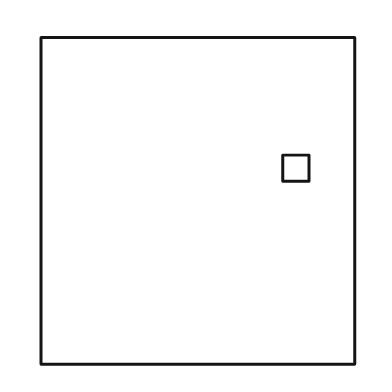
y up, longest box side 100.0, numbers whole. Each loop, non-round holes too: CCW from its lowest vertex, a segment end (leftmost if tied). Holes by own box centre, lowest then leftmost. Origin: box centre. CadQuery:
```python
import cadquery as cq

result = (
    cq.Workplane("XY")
    .moveTo(-48.0, -50.0)
    .lineTo(48.0, -50.0)
    .lineTo(48.0, 50.0)
    .lineTo(-48.0, 50.0)
    .close()
    .moveTo(26.0, 6.0)
    .lineTo(34.0, 6.0)
    .lineTo(34.0, 14.0)
    .lineTo(26.0, 14.0)
    .close()
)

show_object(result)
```